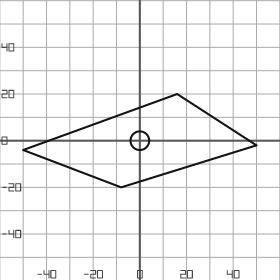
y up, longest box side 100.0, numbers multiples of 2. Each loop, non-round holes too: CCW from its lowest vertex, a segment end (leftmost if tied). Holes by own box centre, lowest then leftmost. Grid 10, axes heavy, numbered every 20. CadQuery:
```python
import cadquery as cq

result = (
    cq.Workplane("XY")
    .moveTo(-8.0, -20.0)
    .lineTo(50.0, -2.0)
    .lineTo(16.0, 20.0)
    .lineTo(-50.0, -4.0)
    .close()
    .moveTo(0.0, 0.0)
    .circle(4.0)
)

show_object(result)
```